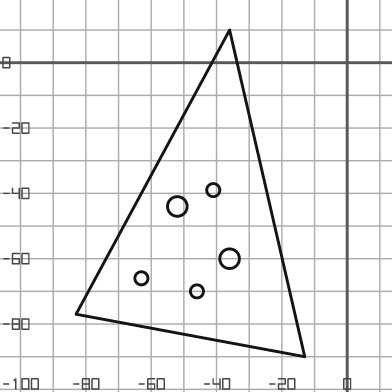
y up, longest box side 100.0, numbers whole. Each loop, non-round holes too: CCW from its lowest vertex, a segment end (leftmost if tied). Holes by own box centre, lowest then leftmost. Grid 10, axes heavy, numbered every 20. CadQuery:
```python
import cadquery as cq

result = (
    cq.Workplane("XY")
    .moveTo(-13.0, -90.0)
    .lineTo(-36.0, 10.0)
    .lineTo(-83.0, -77.0)
    .close()
    .moveTo(-46.0, -70.0)
    .circle(2.0)
    .moveTo(-63.0, -66.0)
    .circle(2.0)
    .moveTo(-36.0, -60.0)
    .circle(3.0)
    .moveTo(-52.0, -44.0)
    .circle(3.0)
    .moveTo(-41.0, -39.0)
    .circle(2.0)
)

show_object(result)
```